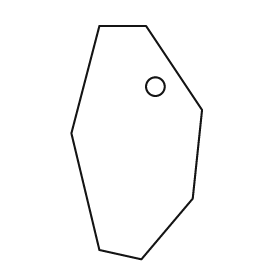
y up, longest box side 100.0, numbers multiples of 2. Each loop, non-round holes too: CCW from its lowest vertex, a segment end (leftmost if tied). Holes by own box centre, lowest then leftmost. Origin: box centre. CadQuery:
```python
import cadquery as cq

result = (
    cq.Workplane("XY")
    .moveTo(2.0, -50.0)
    .lineTo(24.0, -24.0)
    .lineTo(28.0, 14.0)
    .lineTo(4.0, 50.0)
    .lineTo(-16.0, 50.0)
    .lineTo(-28.0, 4.0)
    .lineTo(-16.0, -46.0)
    .close()
    .moveTo(8.0, 24.0)
    .circle(4.0)
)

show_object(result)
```